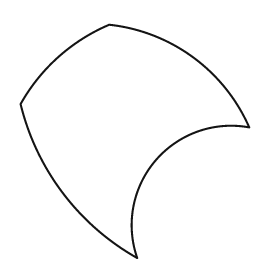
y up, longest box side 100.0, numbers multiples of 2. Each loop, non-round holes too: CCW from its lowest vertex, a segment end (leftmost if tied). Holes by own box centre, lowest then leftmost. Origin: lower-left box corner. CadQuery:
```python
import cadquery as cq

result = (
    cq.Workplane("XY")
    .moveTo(50.0, 0.0)
    .threePointArc((58.0, 42.0), (98.0, 56.0))
    .threePointArc((74.0, 86.0), (38.0, 100.0))
    .threePointArc((16.0, 86.0), (0.0, 66.0))
    .threePointArc((18.0, 28.0), (50.0, 0.0))
    .close()
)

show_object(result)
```